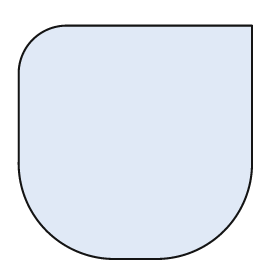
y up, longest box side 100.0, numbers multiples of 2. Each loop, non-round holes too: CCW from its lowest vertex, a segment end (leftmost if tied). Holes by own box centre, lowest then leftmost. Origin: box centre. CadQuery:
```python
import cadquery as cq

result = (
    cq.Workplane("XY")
    .moveTo(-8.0, -50.0)
    .lineTo(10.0, -50.0)
    .threePointArc((38.0, -38.0), (50.0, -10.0))
    .lineTo(50.0, 50.0)
    .lineTo(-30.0, 50.0)
    .threePointArc((-44.0, 44.0), (-50.0, 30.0))
    .lineTo(-50.0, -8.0)
    .threePointArc((-38.0, -38.0), (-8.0, -50.0))
    .close()
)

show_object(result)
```